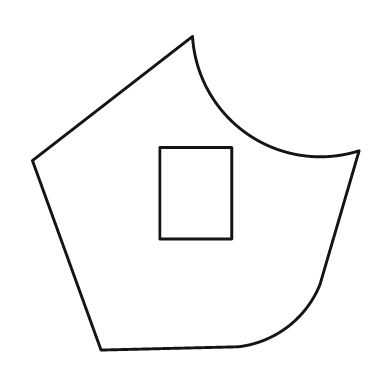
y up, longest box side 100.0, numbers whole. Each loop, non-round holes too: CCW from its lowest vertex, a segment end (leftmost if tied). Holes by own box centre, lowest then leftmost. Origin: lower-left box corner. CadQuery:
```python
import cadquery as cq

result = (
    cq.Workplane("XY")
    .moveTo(21.0, 0.0)
    .lineTo(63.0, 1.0)
    .threePointArc((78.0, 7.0), (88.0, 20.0))
    .lineTo(100.0, 61.0)
    .threePointArc((66.0, 66.0), (49.0, 96.0))
    .lineTo(0.0, 58.0)
    .close()
    .moveTo(39.0, 34.0)
    .lineTo(61.0, 34.0)
    .lineTo(61.0, 62.0)
    .lineTo(39.0, 62.0)
    .close()
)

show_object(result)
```